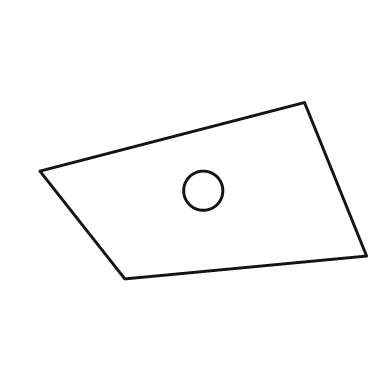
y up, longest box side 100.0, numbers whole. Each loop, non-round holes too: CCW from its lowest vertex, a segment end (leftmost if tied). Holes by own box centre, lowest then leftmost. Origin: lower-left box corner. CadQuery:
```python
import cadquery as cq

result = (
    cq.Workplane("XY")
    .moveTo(26.0, 0.0)
    .lineTo(100.0, 7.0)
    .lineTo(81.0, 54.0)
    .lineTo(0.0, 33.0)
    .close()
    .moveTo(50.0, 27.0)
    .circle(6.0)
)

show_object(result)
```